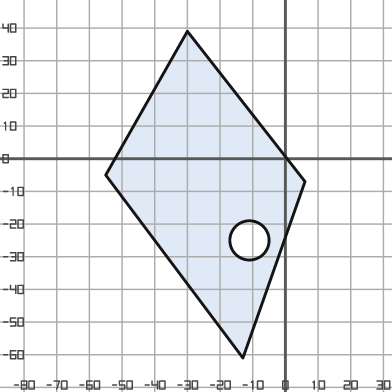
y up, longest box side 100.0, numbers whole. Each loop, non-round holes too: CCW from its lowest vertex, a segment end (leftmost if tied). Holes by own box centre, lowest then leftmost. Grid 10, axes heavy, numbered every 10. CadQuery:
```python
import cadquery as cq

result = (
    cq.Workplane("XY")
    .moveTo(-13.0, -61.0)
    .lineTo(6.0, -7.0)
    .lineTo(-30.0, 39.0)
    .lineTo(-55.0, -5.0)
    .close()
    .moveTo(-11.0, -25.0)
    .circle(6.0)
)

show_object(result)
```